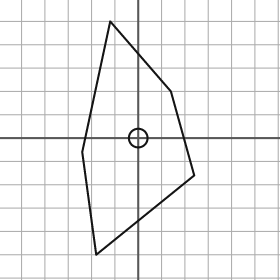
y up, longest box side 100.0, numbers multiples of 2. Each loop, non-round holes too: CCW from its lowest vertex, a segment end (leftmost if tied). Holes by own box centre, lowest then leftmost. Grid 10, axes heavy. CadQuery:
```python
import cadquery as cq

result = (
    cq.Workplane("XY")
    .moveTo(-18.0, -50.0)
    .lineTo(24.0, -16.0)
    .lineTo(14.0, 20.0)
    .lineTo(-12.0, 50.0)
    .lineTo(-24.0, -6.0)
    .close()
    .moveTo(0.0, 0.0)
    .circle(4.0)
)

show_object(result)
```